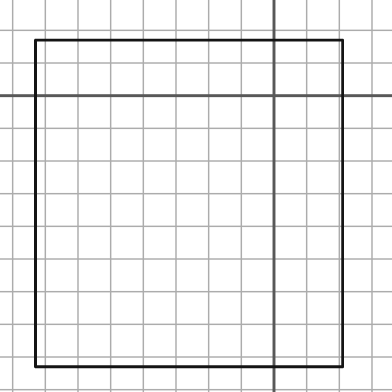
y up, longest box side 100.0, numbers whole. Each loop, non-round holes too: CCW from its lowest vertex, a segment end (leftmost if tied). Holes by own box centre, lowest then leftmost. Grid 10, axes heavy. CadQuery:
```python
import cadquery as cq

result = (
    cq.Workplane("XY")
    .moveTo(-73.0, -83.0)
    .lineTo(21.0, -83.0)
    .lineTo(21.0, 17.0)
    .lineTo(-73.0, 17.0)
    .close()
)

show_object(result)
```